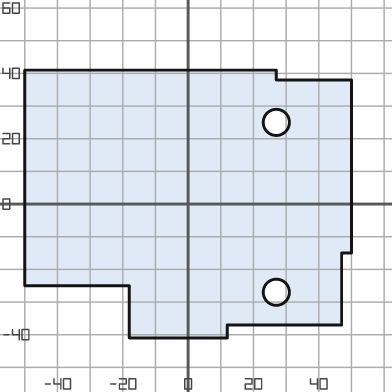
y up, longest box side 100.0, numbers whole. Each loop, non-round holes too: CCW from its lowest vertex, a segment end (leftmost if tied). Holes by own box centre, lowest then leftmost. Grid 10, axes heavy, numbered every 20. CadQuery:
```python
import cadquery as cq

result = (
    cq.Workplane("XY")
    .moveTo(-18.0, -41.0)
    .lineTo(12.0, -41.0)
    .lineTo(12.0, -37.0)
    .lineTo(47.0, -37.0)
    .lineTo(47.0, -15.0)
    .lineTo(50.0, -15.0)
    .lineTo(50.0, 38.0)
    .lineTo(27.0, 38.0)
    .lineTo(27.0, 41.0)
    .lineTo(-50.0, 41.0)
    .lineTo(-50.0, -25.0)
    .lineTo(-18.0, -25.0)
    .close()
    .moveTo(27.0, -27.0)
    .circle(4.0)
    .moveTo(27.0, 25.0)
    .circle(4.0)
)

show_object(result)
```